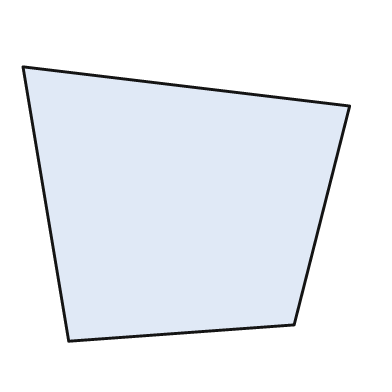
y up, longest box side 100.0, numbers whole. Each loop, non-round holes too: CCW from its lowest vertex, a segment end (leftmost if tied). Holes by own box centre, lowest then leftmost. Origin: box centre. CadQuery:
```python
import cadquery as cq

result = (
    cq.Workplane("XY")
    .moveTo(-36.0, -42.0)
    .lineTo(33.0, -37.0)
    .lineTo(50.0, 30.0)
    .lineTo(-50.0, 42.0)
    .close()
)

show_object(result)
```